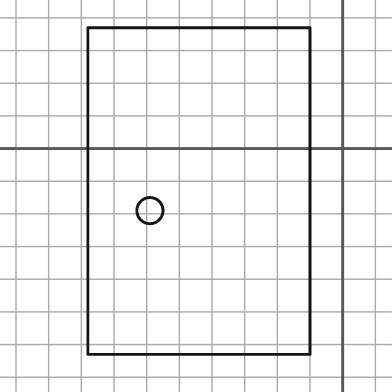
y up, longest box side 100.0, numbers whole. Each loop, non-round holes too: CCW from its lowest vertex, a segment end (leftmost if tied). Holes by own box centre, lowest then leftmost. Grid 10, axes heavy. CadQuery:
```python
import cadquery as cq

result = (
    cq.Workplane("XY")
    .moveTo(-78.0, -63.0)
    .lineTo(-10.0, -63.0)
    .lineTo(-10.0, 37.0)
    .lineTo(-78.0, 37.0)
    .close()
    .moveTo(-59.0, -19.0)
    .circle(4.0)
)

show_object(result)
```